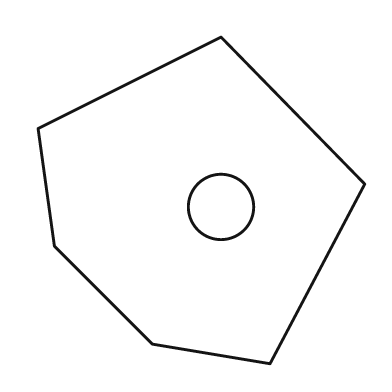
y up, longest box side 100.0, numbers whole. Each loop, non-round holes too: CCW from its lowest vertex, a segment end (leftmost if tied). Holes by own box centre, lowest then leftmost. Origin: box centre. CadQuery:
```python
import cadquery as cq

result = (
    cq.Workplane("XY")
    .moveTo(21.0, -50.0)
    .lineTo(50.0, 5.0)
    .lineTo(6.0, 50.0)
    .lineTo(-50.0, 22.0)
    .lineTo(-45.0, -14.0)
    .lineTo(-15.0, -44.0)
    .close()
    .moveTo(6.0, -2.0)
    .circle(10.0)
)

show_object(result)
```